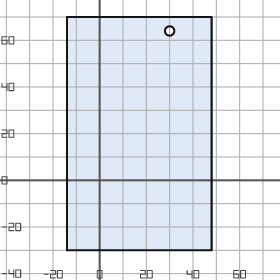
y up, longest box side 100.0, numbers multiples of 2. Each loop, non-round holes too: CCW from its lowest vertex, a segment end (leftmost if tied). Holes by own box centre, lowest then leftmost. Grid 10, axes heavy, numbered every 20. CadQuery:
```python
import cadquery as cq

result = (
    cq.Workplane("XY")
    .moveTo(-14.0, -30.0)
    .lineTo(48.0, -30.0)
    .lineTo(48.0, 70.0)
    .lineTo(-14.0, 70.0)
    .close()
    .moveTo(30.0, 64.0)
    .circle(2.0)
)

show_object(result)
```